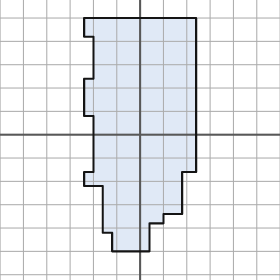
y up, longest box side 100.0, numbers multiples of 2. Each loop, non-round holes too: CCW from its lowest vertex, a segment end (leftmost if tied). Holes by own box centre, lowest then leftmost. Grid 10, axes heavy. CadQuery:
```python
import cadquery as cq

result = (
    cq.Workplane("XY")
    .moveTo(-12.0, -50.0)
    .lineTo(4.0, -50.0)
    .lineTo(4.0, -38.0)
    .lineTo(10.0, -38.0)
    .lineTo(10.0, -34.0)
    .lineTo(18.0, -34.0)
    .lineTo(18.0, -16.0)
    .lineTo(24.0, -16.0)
    .lineTo(24.0, 50.0)
    .lineTo(-24.0, 50.0)
    .lineTo(-24.0, 42.0)
    .lineTo(-20.0, 42.0)
    .lineTo(-20.0, 24.0)
    .lineTo(-24.0, 24.0)
    .lineTo(-24.0, 8.0)
    .lineTo(-20.0, 8.0)
    .lineTo(-20.0, -16.0)
    .lineTo(-24.0, -16.0)
    .lineTo(-24.0, -22.0)
    .lineTo(-16.0, -22.0)
    .lineTo(-16.0, -42.0)
    .lineTo(-12.0, -42.0)
    .close()
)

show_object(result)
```